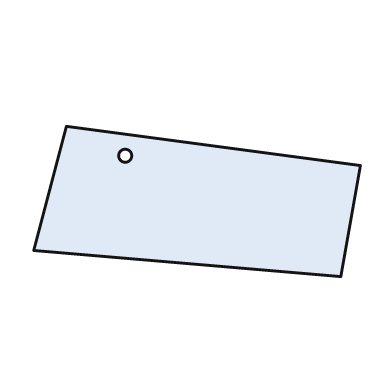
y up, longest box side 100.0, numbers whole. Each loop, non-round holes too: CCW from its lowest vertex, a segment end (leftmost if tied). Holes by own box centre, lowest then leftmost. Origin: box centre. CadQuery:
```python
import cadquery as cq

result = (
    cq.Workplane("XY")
    .moveTo(44.0, -23.0)
    .lineTo(50.0, 11.0)
    .lineTo(-40.0, 23.0)
    .lineTo(-50.0, -15.0)
    .close()
    .moveTo(-22.0, 14.0)
    .circle(2.0)
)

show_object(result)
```